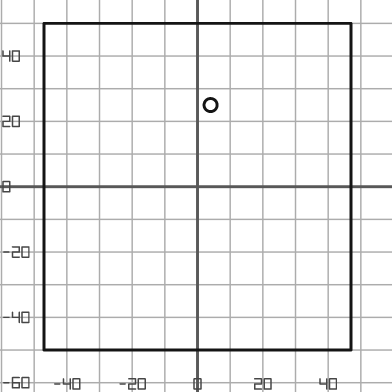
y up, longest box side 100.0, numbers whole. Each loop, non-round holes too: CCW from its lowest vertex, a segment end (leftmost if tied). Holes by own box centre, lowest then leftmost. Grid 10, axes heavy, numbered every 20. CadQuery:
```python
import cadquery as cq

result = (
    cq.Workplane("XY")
    .moveTo(-47.0, -50.0)
    .lineTo(47.0, -50.0)
    .lineTo(47.0, 50.0)
    .lineTo(-47.0, 50.0)
    .close()
    .moveTo(4.0, 25.0)
    .circle(2.0)
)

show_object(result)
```